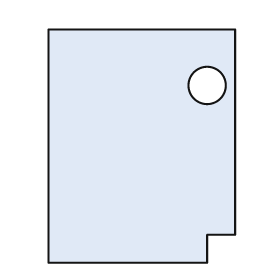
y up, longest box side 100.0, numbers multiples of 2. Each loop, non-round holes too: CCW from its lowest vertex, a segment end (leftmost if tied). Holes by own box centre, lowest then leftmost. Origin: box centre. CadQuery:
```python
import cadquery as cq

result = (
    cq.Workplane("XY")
    .moveTo(-40.0, -50.0)
    .lineTo(28.0, -50.0)
    .lineTo(28.0, -38.0)
    .lineTo(40.0, -38.0)
    .lineTo(40.0, 50.0)
    .lineTo(-40.0, 50.0)
    .close()
    .moveTo(28.0, 26.0)
    .circle(8.0)
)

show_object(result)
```